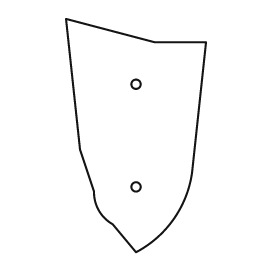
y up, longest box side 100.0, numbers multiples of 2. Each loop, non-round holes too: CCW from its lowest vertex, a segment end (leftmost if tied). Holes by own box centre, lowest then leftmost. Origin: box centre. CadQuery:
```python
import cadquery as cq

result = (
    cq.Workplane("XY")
    .moveTo(0.0, -50.0)
    .threePointArc((16.0, -36.0), (24.0, -16.0))
    .lineTo(30.0, 40.0)
    .lineTo(8.0, 40.0)
    .lineTo(-30.0, 50.0)
    .lineTo(-24.0, -6.0)
    .lineTo(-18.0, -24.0)
    .threePointArc((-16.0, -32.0), (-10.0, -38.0))
    .close()
    .moveTo(0.0, -22.0)
    .circle(2.0)
    .moveTo(0.0, 22.0)
    .circle(2.0)
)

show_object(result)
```